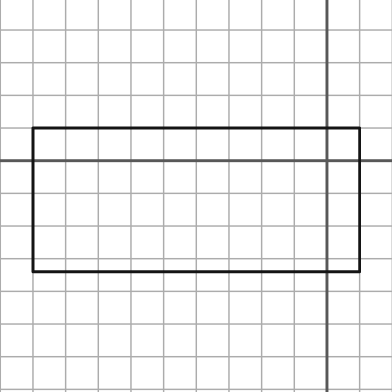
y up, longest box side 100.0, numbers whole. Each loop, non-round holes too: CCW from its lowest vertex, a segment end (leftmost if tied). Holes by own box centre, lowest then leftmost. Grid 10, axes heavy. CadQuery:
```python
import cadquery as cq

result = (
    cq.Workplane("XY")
    .moveTo(-90.0, -34.0)
    .lineTo(10.0, -34.0)
    .lineTo(10.0, 10.0)
    .lineTo(-90.0, 10.0)
    .close()
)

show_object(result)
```